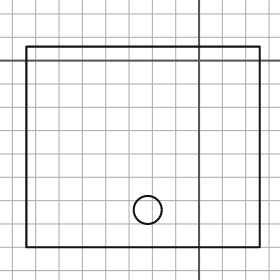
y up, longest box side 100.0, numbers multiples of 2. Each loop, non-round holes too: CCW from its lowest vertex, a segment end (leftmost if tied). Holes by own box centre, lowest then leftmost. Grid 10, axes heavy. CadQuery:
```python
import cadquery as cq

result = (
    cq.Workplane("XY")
    .moveTo(-74.0, -80.0)
    .lineTo(26.0, -80.0)
    .lineTo(26.0, 6.0)
    .lineTo(-74.0, 6.0)
    .close()
    .moveTo(-22.0, -64.0)
    .circle(6.0)
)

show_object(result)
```